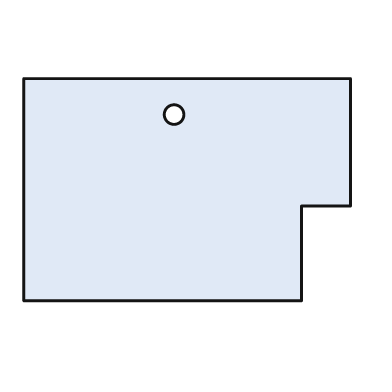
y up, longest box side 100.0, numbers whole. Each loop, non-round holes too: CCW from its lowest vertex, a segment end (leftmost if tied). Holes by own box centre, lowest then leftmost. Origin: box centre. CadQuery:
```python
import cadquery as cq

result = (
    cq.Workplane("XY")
    .moveTo(-50.0, -34.0)
    .lineTo(35.0, -34.0)
    .lineTo(35.0, -5.0)
    .lineTo(50.0, -5.0)
    .lineTo(50.0, 34.0)
    .lineTo(-50.0, 34.0)
    .close()
    .moveTo(-4.0, 23.0)
    .circle(3.0)
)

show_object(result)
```